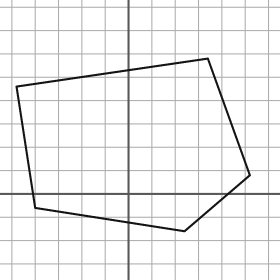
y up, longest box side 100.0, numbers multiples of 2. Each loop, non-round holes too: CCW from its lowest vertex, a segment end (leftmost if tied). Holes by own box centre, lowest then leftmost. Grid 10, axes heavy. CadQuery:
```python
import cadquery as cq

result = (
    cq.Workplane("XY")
    .moveTo(24.0, -16.0)
    .lineTo(52.0, 8.0)
    .lineTo(34.0, 58.0)
    .lineTo(-48.0, 46.0)
    .lineTo(-40.0, -6.0)
    .close()
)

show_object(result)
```